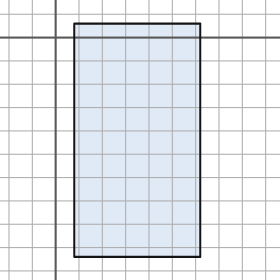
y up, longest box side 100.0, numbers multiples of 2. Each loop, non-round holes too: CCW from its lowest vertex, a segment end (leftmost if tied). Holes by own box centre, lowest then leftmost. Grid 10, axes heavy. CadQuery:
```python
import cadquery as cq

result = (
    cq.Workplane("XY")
    .moveTo(8.0, -94.0)
    .lineTo(62.0, -94.0)
    .lineTo(62.0, 6.0)
    .lineTo(8.0, 6.0)
    .close()
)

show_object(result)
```